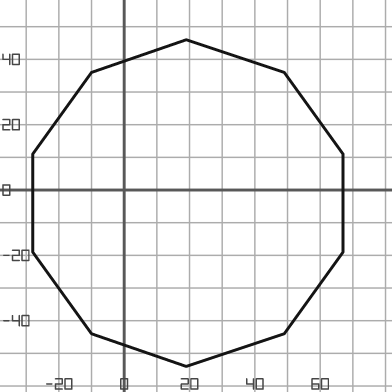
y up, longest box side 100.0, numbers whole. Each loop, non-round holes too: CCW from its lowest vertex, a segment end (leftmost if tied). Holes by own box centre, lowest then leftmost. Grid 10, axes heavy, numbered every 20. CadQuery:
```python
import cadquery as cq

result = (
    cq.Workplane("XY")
    .moveTo(19.0, -54.0)
    .lineTo(49.0, -44.0)
    .lineTo(67.0, -19.0)
    .lineTo(67.0, 11.0)
    .lineTo(49.0, 36.0)
    .lineTo(19.0, 46.0)
    .lineTo(-10.0, 36.0)
    .lineTo(-28.0, 11.0)
    .lineTo(-28.0, -19.0)
    .lineTo(-10.0, -44.0)
    .close()
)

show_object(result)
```